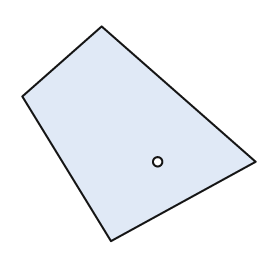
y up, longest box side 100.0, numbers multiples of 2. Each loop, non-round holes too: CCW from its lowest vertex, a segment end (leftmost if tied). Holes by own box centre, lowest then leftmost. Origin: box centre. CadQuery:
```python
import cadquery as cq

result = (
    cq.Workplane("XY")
    .moveTo(-12.0, -46.0)
    .lineTo(50.0, -12.0)
    .lineTo(-16.0, 46.0)
    .lineTo(-50.0, 16.0)
    .close()
    .moveTo(8.0, -12.0)
    .circle(2.0)
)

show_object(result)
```